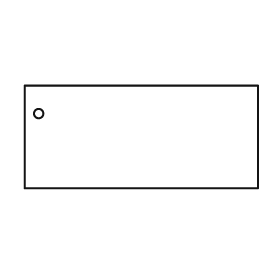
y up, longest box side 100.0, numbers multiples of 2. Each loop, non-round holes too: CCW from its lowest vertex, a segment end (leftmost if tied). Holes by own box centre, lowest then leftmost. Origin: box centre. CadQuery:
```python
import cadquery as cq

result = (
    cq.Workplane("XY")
    .moveTo(-50.0, -22.0)
    .lineTo(50.0, -22.0)
    .lineTo(50.0, 22.0)
    .lineTo(-50.0, 22.0)
    .close()
    .moveTo(-44.0, 10.0)
    .circle(2.0)
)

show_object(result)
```